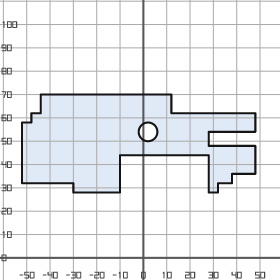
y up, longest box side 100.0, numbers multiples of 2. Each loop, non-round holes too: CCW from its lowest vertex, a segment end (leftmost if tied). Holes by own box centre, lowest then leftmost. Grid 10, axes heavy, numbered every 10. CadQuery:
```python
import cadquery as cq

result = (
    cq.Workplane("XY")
    .moveTo(-30.0, 28.0)
    .lineTo(-10.0, 28.0)
    .lineTo(-10.0, 44.0)
    .lineTo(28.0, 44.0)
    .lineTo(28.0, 28.0)
    .lineTo(32.0, 28.0)
    .lineTo(32.0, 32.0)
    .lineTo(38.0, 32.0)
    .lineTo(38.0, 36.0)
    .lineTo(48.0, 36.0)
    .lineTo(48.0, 48.0)
    .lineTo(28.0, 48.0)
    .lineTo(28.0, 54.0)
    .lineTo(48.0, 54.0)
    .lineTo(48.0, 62.0)
    .lineTo(12.0, 62.0)
    .lineTo(12.0, 70.0)
    .lineTo(-44.0, 70.0)
    .lineTo(-44.0, 62.0)
    .lineTo(-48.0, 62.0)
    .lineTo(-48.0, 58.0)
    .lineTo(-52.0, 58.0)
    .lineTo(-52.0, 32.0)
    .lineTo(-30.0, 32.0)
    .close()
    .moveTo(2.0, 54.0)
    .circle(4.0)
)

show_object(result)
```